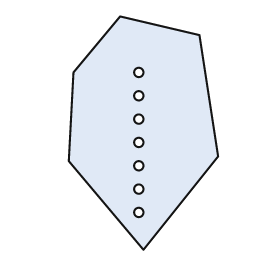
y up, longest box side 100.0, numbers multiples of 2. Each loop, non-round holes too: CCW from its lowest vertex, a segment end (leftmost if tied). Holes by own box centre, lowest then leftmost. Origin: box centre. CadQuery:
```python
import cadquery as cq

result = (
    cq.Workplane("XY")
    .moveTo(0.0, -50.0)
    .lineTo(32.0, -10.0)
    .lineTo(24.0, 42.0)
    .lineTo(-10.0, 50.0)
    .lineTo(-30.0, 26.0)
    .lineTo(-32.0, -12.0)
    .close()
    .moveTo(-2.0, -34.0)
    .circle(2.0)
    .moveTo(-2.0, -24.0)
    .circle(2.0)
    .moveTo(-2.0, -14.0)
    .circle(2.0)
    .moveTo(-2.0, -4.0)
    .circle(2.0)
    .moveTo(-2.0, 6.0)
    .circle(2.0)
    .moveTo(-2.0, 16.0)
    .circle(2.0)
    .moveTo(-2.0, 26.0)
    .circle(2.0)
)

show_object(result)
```